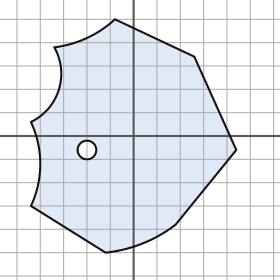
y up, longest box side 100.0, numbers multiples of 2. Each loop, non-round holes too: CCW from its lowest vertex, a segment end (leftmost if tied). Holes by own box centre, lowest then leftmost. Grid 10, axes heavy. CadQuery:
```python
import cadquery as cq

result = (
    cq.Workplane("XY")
    .moveTo(-12.0, -50.0)
    .threePointArc((4.0, -46.0), (18.0, -38.0))
    .lineTo(44.0, -6.0)
    .lineTo(26.0, 34.0)
    .lineTo(-8.0, 50.0)
    .threePointArc((-20.0, 42.0), (-34.0, 38.0))
    .threePointArc((-32.0, 20.0), (-44.0, 6.0))
    .threePointArc((-40.0, -12.0), (-44.0, -30.0))
    .close()
    .moveTo(-20.0, -6.0)
    .circle(4.0)
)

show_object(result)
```